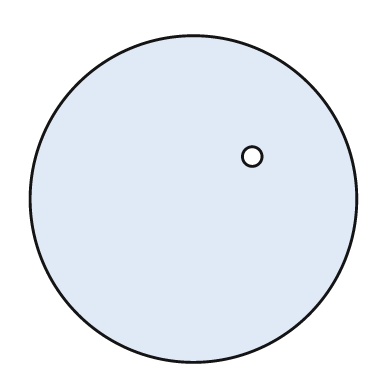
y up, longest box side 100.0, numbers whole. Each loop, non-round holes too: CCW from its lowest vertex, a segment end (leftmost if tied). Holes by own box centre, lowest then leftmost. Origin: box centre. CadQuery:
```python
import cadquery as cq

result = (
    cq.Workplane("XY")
    .moveTo(0.0, 0.0)
    .circle(50.0)
    .moveTo(18.0, 13.0)
    .circle(3.0)
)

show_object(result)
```